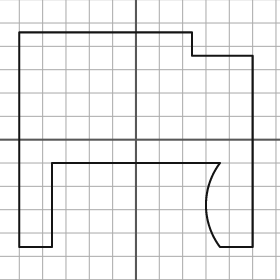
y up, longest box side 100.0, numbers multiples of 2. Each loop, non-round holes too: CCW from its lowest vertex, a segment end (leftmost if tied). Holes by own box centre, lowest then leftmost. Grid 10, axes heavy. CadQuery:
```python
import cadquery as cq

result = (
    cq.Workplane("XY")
    .moveTo(-50.0, -46.0)
    .lineTo(-36.0, -46.0)
    .lineTo(-36.0, -10.0)
    .lineTo(36.0, -10.0)
    .threePointArc((30.0, -28.0), (36.0, -46.0))
    .lineTo(50.0, -46.0)
    .lineTo(50.0, 36.0)
    .lineTo(24.0, 36.0)
    .lineTo(24.0, 46.0)
    .lineTo(-50.0, 46.0)
    .close()
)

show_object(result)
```